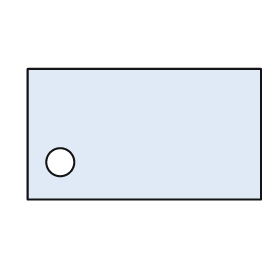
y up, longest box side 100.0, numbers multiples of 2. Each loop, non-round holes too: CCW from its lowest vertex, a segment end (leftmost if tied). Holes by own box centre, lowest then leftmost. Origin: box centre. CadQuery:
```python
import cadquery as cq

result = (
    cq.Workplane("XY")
    .moveTo(-50.0, -28.0)
    .lineTo(50.0, -28.0)
    .lineTo(50.0, 28.0)
    .lineTo(-50.0, 28.0)
    .close()
    .moveTo(-36.0, -12.0)
    .circle(6.0)
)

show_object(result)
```